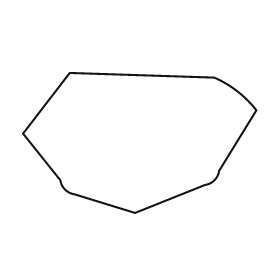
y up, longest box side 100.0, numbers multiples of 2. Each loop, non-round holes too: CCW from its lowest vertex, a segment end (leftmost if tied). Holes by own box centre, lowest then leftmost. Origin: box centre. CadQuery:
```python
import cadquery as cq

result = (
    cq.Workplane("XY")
    .moveTo(-2.0, -30.0)
    .lineTo(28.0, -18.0)
    .threePointArc((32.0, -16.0), (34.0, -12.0))
    .lineTo(50.0, 14.0)
    .threePointArc((42.0, 22.0), (32.0, 28.0))
    .lineTo(-30.0, 30.0)
    .lineTo(-50.0, 4.0)
    .lineTo(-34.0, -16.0)
    .threePointArc((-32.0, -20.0), (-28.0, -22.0))
    .close()
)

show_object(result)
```